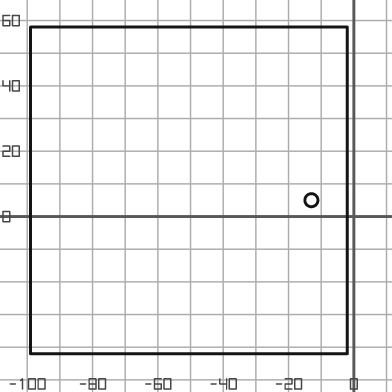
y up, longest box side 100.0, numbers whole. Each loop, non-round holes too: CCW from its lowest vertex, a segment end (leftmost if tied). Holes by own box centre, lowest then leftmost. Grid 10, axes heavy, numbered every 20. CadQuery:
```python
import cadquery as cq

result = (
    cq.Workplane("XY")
    .moveTo(-99.0, -42.0)
    .lineTo(-2.0, -42.0)
    .lineTo(-2.0, 58.0)
    .lineTo(-99.0, 58.0)
    .close()
    .moveTo(-13.0, 5.0)
    .circle(2.0)
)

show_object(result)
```